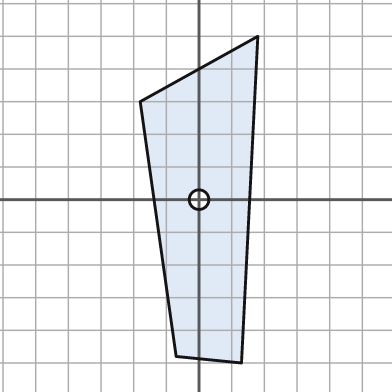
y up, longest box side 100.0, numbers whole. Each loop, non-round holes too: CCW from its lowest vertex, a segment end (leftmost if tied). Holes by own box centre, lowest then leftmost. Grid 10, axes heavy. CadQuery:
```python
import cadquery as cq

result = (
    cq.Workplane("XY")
    .moveTo(13.0, -50.0)
    .lineTo(18.0, 50.0)
    .lineTo(-18.0, 30.0)
    .lineTo(-7.0, -48.0)
    .close()
    .moveTo(0.0, 0.0)
    .circle(3.0)
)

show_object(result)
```